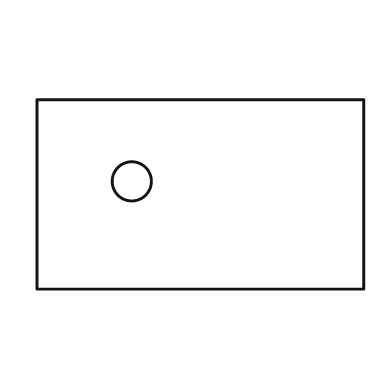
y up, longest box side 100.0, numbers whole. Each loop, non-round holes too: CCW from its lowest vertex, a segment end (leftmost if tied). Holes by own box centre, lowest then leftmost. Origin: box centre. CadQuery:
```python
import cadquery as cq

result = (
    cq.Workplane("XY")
    .moveTo(-50.0, -29.0)
    .lineTo(50.0, -29.0)
    .lineTo(50.0, 29.0)
    .lineTo(-50.0, 29.0)
    .close()
    .moveTo(-21.0, 4.0)
    .circle(6.0)
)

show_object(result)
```